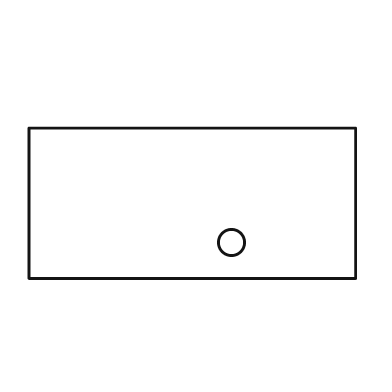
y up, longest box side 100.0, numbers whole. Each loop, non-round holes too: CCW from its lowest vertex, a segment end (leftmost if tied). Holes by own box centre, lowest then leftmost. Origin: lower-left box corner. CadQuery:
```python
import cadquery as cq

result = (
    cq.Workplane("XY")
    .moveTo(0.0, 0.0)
    .lineTo(100.0, 0.0)
    .lineTo(100.0, 46.0)
    .lineTo(0.0, 46.0)
    .close()
    .moveTo(62.0, 11.0)
    .circle(4.0)
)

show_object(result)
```